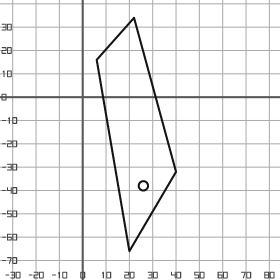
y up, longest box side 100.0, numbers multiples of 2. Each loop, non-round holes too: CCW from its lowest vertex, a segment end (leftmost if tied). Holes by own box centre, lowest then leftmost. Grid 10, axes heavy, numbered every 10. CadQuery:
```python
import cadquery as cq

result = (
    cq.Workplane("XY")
    .moveTo(20.0, -66.0)
    .lineTo(40.0, -32.0)
    .lineTo(22.0, 34.0)
    .lineTo(6.0, 16.0)
    .close()
    .moveTo(26.0, -38.0)
    .circle(2.0)
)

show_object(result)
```